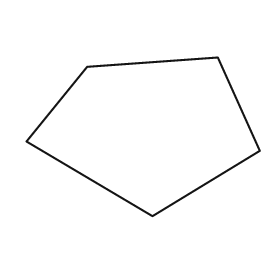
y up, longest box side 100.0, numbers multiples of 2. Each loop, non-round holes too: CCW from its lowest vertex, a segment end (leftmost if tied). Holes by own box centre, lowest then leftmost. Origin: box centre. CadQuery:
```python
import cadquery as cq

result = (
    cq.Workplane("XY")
    .moveTo(4.0, -34.0)
    .lineTo(50.0, -6.0)
    .lineTo(32.0, 34.0)
    .lineTo(-24.0, 30.0)
    .lineTo(-50.0, -2.0)
    .close()
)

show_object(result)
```